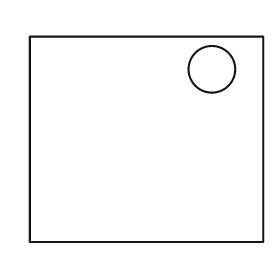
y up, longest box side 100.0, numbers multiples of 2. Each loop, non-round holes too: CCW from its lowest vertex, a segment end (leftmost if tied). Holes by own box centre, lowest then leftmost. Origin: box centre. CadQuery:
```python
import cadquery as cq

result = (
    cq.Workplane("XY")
    .moveTo(-50.0, -44.0)
    .lineTo(50.0, -44.0)
    .lineTo(50.0, 44.0)
    .lineTo(-50.0, 44.0)
    .close()
    .moveTo(28.0, 30.0)
    .circle(10.0)
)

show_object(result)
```